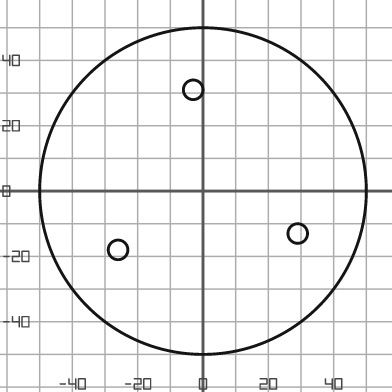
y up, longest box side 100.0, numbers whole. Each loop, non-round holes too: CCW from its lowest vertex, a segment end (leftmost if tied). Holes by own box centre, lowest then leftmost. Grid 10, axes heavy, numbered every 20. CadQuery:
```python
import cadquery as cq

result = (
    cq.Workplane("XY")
    .moveTo(0.0, 0.0)
    .circle(50.0)
    .moveTo(-26.0, -18.0)
    .circle(3.0)
    .moveTo(29.0, -13.0)
    .circle(3.0)
    .moveTo(-3.0, 31.0)
    .circle(3.0)
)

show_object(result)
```